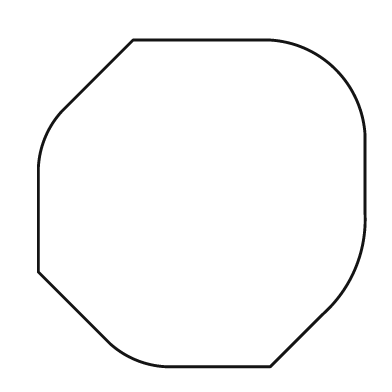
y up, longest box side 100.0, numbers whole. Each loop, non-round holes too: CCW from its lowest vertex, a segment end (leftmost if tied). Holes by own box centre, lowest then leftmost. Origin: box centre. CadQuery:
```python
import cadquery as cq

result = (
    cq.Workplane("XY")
    .moveTo(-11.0, -50.0)
    .lineTo(21.0, -50.0)
    .lineTo(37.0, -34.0)
    .threePointArc((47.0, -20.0), (50.0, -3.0))
    .lineTo(50.0, 21.0)
    .threePointArc((41.0, 41.0), (21.0, 50.0))
    .lineTo(-21.0, 50.0)
    .lineTo(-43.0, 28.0)
    .threePointArc((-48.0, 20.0), (-50.0, 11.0))
    .lineTo(-50.0, -21.0)
    .lineTo(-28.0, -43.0)
    .threePointArc((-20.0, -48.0), (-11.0, -50.0))
    .close()
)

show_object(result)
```